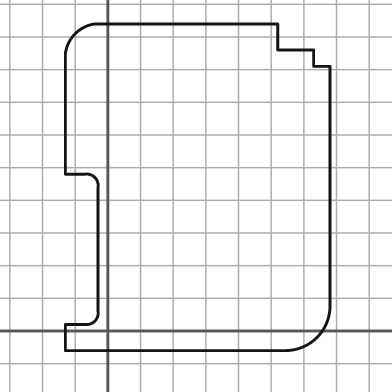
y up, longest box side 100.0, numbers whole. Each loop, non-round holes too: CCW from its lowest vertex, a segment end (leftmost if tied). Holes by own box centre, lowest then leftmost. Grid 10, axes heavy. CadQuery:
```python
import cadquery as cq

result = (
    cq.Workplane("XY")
    .moveTo(-13.0, -6.0)
    .lineTo(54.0, -6.0)
    .threePointArc((64.0, -2.0), (68.0, 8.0))
    .lineTo(68.0, 81.0)
    .lineTo(63.0, 81.0)
    .lineTo(63.0, 86.0)
    .lineTo(52.0, 86.0)
    .lineTo(52.0, 94.0)
    .lineTo(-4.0, 94.0)
    .threePointArc((-10.0, 91.0), (-13.0, 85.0))
    .lineTo(-13.0, 48.0)
    .lineTo(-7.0, 48.0)
    .threePointArc((-4.0, 47.0), (-3.0, 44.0))
    .lineTo(-3.0, 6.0)
    .threePointArc((-4.0, 3.0), (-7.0, 2.0))
    .lineTo(-13.0, 2.0)
    .close()
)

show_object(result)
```